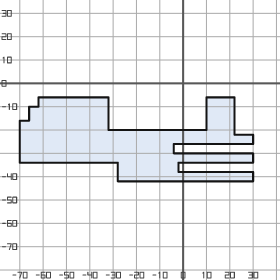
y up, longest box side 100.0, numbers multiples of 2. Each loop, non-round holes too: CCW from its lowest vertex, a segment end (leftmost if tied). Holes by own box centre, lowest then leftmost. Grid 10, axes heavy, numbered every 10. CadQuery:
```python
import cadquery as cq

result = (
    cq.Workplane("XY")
    .moveTo(-28.0, -42.0)
    .lineTo(30.0, -42.0)
    .lineTo(30.0, -38.0)
    .lineTo(-2.0, -38.0)
    .lineTo(-2.0, -34.0)
    .lineTo(30.0, -34.0)
    .lineTo(30.0, -30.0)
    .lineTo(-4.0, -30.0)
    .lineTo(-4.0, -26.0)
    .lineTo(30.0, -26.0)
    .lineTo(30.0, -22.0)
    .lineTo(22.0, -22.0)
    .lineTo(22.0, -6.0)
    .lineTo(10.0, -6.0)
    .lineTo(10.0, -20.0)
    .lineTo(-32.0, -20.0)
    .lineTo(-32.0, -6.0)
    .lineTo(-62.0, -6.0)
    .lineTo(-62.0, -10.0)
    .lineTo(-66.0, -10.0)
    .lineTo(-66.0, -16.0)
    .lineTo(-70.0, -16.0)
    .lineTo(-70.0, -34.0)
    .lineTo(-28.0, -34.0)
    .close()
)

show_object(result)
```